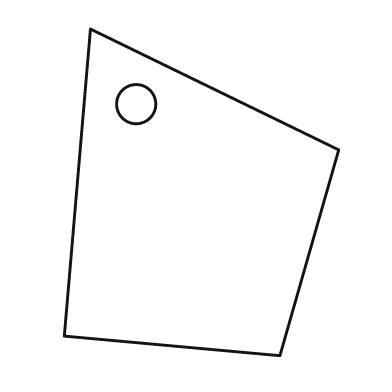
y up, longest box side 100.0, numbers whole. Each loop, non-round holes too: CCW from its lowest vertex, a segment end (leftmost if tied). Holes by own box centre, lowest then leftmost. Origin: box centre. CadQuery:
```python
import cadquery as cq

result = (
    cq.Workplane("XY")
    .moveTo(24.0, -50.0)
    .lineTo(42.0, 13.0)
    .lineTo(-34.0, 50.0)
    .lineTo(-42.0, -44.0)
    .close()
    .moveTo(-20.0, 27.0)
    .circle(6.0)
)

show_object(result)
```